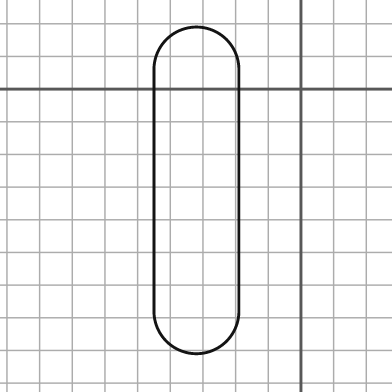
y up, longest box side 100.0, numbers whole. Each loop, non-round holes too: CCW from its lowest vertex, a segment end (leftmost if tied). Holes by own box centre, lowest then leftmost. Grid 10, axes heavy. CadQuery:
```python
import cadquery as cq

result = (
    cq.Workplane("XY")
    .moveTo(-45.0, -68.0)
    .threePointArc((-32.0, -81.0), (-19.0, -68.0))
    .lineTo(-19.0, 6.0)
    .threePointArc((-32.0, 19.0), (-45.0, 6.0))
    .close()
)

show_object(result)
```